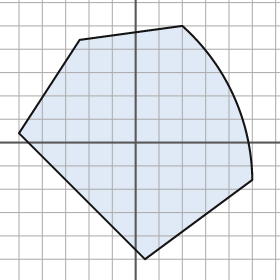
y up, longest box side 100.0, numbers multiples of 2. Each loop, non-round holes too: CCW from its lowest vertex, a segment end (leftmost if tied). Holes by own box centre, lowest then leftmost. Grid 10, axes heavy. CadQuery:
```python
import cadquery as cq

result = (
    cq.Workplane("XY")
    .moveTo(4.0, -50.0)
    .lineTo(50.0, -16.0)
    .threePointArc((42.0, 20.0), (20.0, 50.0))
    .lineTo(-24.0, 44.0)
    .lineTo(-50.0, 4.0)
    .close()
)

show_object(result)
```